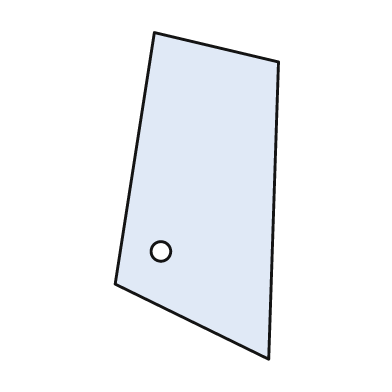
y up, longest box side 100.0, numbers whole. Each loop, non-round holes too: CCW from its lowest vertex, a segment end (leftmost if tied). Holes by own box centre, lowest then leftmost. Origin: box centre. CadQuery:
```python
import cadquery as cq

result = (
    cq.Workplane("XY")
    .moveTo(22.0, -50.0)
    .lineTo(25.0, 41.0)
    .lineTo(-13.0, 50.0)
    .lineTo(-25.0, -27.0)
    .close()
    .moveTo(-11.0, -17.0)
    .circle(3.0)
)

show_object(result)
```